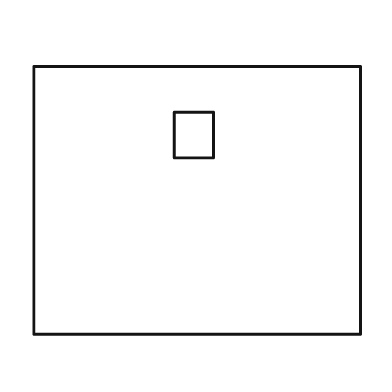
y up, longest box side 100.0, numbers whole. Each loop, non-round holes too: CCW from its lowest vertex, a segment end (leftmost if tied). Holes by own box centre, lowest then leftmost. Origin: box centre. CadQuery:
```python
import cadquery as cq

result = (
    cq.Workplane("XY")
    .moveTo(-50.0, -41.0)
    .lineTo(50.0, -41.0)
    .lineTo(50.0, 41.0)
    .lineTo(-50.0, 41.0)
    .close()
    .moveTo(-7.0, 13.0)
    .lineTo(5.0, 13.0)
    .lineTo(5.0, 27.0)
    .lineTo(-7.0, 27.0)
    .close()
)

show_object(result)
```